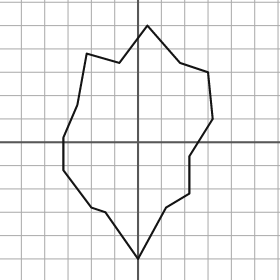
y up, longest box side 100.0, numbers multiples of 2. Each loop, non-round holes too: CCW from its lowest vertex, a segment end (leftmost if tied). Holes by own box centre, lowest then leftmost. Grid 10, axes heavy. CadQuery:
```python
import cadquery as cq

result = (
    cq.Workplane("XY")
    .moveTo(0.0, -50.0)
    .lineTo(12.0, -28.0)
    .lineTo(22.0, -22.0)
    .lineTo(22.0, -6.0)
    .lineTo(32.0, 10.0)
    .lineTo(30.0, 30.0)
    .lineTo(18.0, 34.0)
    .lineTo(4.0, 50.0)
    .lineTo(-8.0, 34.0)
    .lineTo(-22.0, 38.0)
    .lineTo(-26.0, 16.0)
    .lineTo(-32.0, 2.0)
    .lineTo(-32.0, -12.0)
    .lineTo(-20.0, -28.0)
    .lineTo(-14.0, -30.0)
    .close()
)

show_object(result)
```